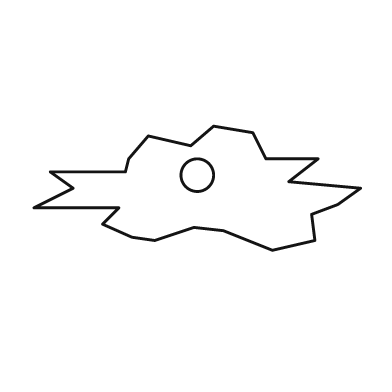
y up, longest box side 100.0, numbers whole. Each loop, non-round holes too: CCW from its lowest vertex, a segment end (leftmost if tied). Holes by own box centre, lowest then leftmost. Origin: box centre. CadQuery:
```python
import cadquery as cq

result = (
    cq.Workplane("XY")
    .moveTo(23.0, -19.0)
    .lineTo(36.0, -16.0)
    .lineTo(35.0, -8.0)
    .lineTo(43.0, -5.0)
    .lineTo(50.0, 0.0)
    .lineTo(28.0, 2.0)
    .lineTo(37.0, 9.0)
    .lineTo(21.0, 9.0)
    .lineTo(17.0, 17.0)
    .lineTo(5.0, 19.0)
    .lineTo(-2.0, 13.0)
    .lineTo(-15.0, 16.0)
    .lineTo(-21.0, 9.0)
    .lineTo(-22.0, 5.0)
    .lineTo(-45.0, 5.0)
    .lineTo(-38.0, 0.0)
    .lineTo(-50.0, -6.0)
    .lineTo(-24.0, -6.0)
    .lineTo(-29.0, -11.0)
    .lineTo(-20.0, -15.0)
    .lineTo(-13.0, -16.0)
    .lineTo(-1.0, -12.0)
    .lineTo(8.0, -13.0)
    .close()
    .moveTo(0.0, 4.0)
    .circle(5.0)
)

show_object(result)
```